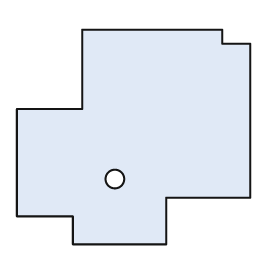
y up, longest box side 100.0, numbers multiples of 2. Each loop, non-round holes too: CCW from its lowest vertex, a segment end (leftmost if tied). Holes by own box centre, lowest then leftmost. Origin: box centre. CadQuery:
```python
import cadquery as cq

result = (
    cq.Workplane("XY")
    .moveTo(-26.0, -46.0)
    .lineTo(14.0, -46.0)
    .lineTo(14.0, -26.0)
    .lineTo(50.0, -26.0)
    .lineTo(50.0, 40.0)
    .lineTo(38.0, 40.0)
    .lineTo(38.0, 46.0)
    .lineTo(-22.0, 46.0)
    .lineTo(-22.0, 12.0)
    .lineTo(-50.0, 12.0)
    .lineTo(-50.0, -34.0)
    .lineTo(-26.0, -34.0)
    .close()
    .moveTo(-8.0, -18.0)
    .circle(4.0)
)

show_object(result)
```